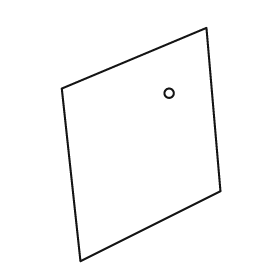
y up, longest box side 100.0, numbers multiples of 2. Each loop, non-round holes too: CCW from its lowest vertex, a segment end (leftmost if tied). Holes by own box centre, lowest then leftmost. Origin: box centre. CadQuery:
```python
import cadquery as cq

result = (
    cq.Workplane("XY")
    .moveTo(-26.0, -50.0)
    .lineTo(34.0, -20.0)
    .lineTo(28.0, 50.0)
    .lineTo(-34.0, 24.0)
    .close()
    .moveTo(12.0, 22.0)
    .circle(2.0)
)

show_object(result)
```